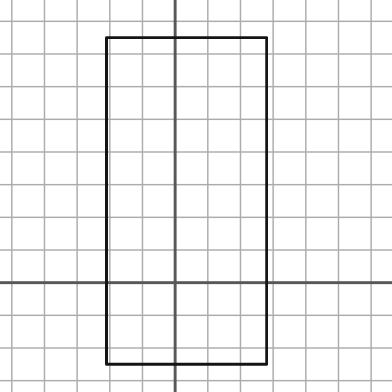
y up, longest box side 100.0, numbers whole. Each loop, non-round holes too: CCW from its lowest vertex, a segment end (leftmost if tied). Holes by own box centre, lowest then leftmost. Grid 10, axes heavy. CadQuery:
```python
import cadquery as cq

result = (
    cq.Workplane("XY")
    .moveTo(-21.0, -25.0)
    .lineTo(28.0, -25.0)
    .lineTo(28.0, 75.0)
    .lineTo(-21.0, 75.0)
    .close()
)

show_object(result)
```